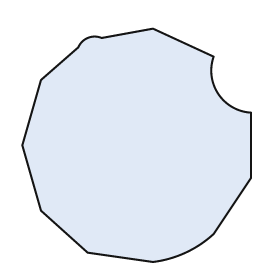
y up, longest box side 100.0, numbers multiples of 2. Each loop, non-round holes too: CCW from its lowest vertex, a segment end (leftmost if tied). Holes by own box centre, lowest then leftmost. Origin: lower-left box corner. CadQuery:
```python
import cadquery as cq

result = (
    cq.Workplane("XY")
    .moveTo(56.0, 0.0)
    .threePointArc((70.0, 4.0), (82.0, 12.0))
    .lineTo(98.0, 36.0)
    .lineTo(98.0, 64.0)
    .threePointArc((84.0, 72.0), (82.0, 88.0))
    .lineTo(56.0, 100.0)
    .lineTo(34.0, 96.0)
    .threePointArc((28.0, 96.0), (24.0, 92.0))
    .lineTo(8.0, 78.0)
    .lineTo(0.0, 50.0)
    .lineTo(8.0, 22.0)
    .lineTo(28.0, 4.0)
    .close()
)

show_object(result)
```